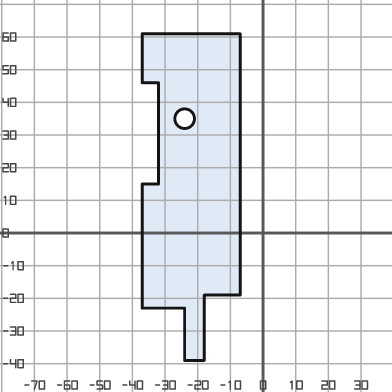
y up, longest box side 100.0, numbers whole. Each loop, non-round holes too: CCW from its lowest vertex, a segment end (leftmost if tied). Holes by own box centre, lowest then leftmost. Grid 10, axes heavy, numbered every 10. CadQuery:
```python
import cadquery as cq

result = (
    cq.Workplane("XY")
    .moveTo(-24.0, -39.0)
    .lineTo(-18.0, -39.0)
    .lineTo(-18.0, -19.0)
    .lineTo(-7.0, -19.0)
    .lineTo(-7.0, 61.0)
    .lineTo(-37.0, 61.0)
    .lineTo(-37.0, 46.0)
    .lineTo(-32.0, 46.0)
    .lineTo(-32.0, 15.0)
    .lineTo(-37.0, 15.0)
    .lineTo(-37.0, -23.0)
    .lineTo(-24.0, -23.0)
    .close()
    .moveTo(-24.0, 35.0)
    .circle(3.0)
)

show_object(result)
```